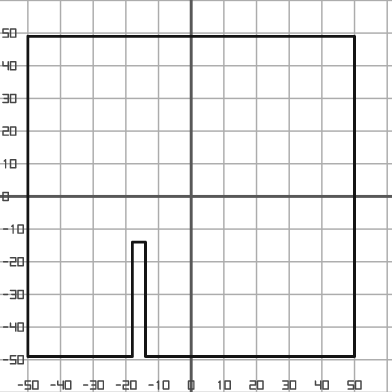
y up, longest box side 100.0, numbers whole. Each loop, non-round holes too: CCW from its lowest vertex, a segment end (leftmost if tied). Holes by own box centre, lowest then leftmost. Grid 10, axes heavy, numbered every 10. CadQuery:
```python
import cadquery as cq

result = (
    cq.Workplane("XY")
    .moveTo(-50.0, -49.0)
    .lineTo(-18.0, -49.0)
    .lineTo(-18.0, -14.0)
    .lineTo(-14.0, -14.0)
    .lineTo(-14.0, -49.0)
    .lineTo(50.0, -49.0)
    .lineTo(50.0, 49.0)
    .lineTo(-50.0, 49.0)
    .close()
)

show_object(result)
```